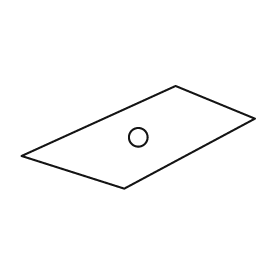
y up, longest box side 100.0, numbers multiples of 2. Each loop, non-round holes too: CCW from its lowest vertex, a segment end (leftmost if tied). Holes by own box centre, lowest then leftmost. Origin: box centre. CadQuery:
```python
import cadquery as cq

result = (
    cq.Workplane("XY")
    .moveTo(-6.0, -22.0)
    .lineTo(50.0, 8.0)
    .lineTo(16.0, 22.0)
    .lineTo(-50.0, -8.0)
    .close()
    .moveTo(0.0, 0.0)
    .circle(4.0)
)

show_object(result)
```